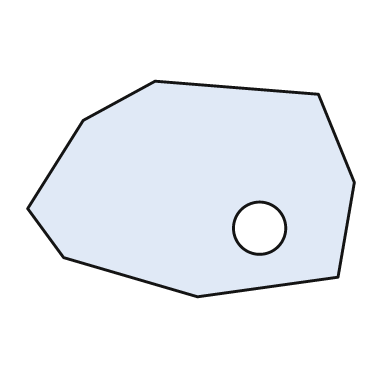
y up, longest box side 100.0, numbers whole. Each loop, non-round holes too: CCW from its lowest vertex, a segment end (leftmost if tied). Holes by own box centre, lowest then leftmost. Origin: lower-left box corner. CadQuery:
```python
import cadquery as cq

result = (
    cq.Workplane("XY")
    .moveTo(52.0, 0.0)
    .lineTo(95.0, 6.0)
    .lineTo(100.0, 35.0)
    .lineTo(89.0, 62.0)
    .lineTo(39.0, 66.0)
    .lineTo(17.0, 54.0)
    .lineTo(0.0, 27.0)
    .lineTo(11.0, 12.0)
    .close()
    .moveTo(71.0, 21.0)
    .circle(8.0)
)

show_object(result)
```